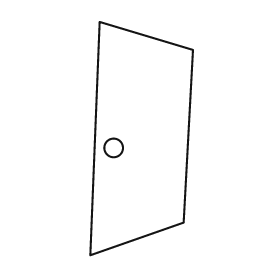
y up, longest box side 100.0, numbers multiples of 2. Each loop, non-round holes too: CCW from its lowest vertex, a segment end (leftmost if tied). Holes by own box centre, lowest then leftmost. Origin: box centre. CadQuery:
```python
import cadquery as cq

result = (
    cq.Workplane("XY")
    .moveTo(-22.0, -50.0)
    .lineTo(18.0, -36.0)
    .lineTo(22.0, 38.0)
    .lineTo(-18.0, 50.0)
    .close()
    .moveTo(-12.0, -4.0)
    .circle(4.0)
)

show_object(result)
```